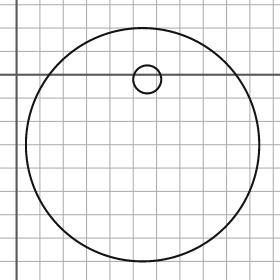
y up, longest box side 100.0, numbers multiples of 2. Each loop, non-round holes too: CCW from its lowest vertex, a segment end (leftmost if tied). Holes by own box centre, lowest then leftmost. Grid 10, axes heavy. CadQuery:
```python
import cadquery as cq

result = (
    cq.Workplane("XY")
    .moveTo(54.0, -30.0)
    .circle(50.0)
    .moveTo(56.0, -2.0)
    .circle(6.0)
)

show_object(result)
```